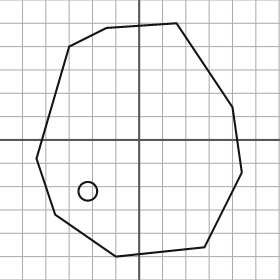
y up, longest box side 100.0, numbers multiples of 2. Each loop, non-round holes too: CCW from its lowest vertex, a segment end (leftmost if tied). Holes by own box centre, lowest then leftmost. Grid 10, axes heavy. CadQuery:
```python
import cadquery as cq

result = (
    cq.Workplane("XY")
    .moveTo(-10.0, -50.0)
    .lineTo(28.0, -46.0)
    .lineTo(44.0, -14.0)
    .lineTo(40.0, 14.0)
    .lineTo(16.0, 50.0)
    .lineTo(-14.0, 48.0)
    .lineTo(-30.0, 40.0)
    .lineTo(-44.0, -8.0)
    .lineTo(-36.0, -32.0)
    .close()
    .moveTo(-22.0, -22.0)
    .circle(4.0)
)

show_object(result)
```